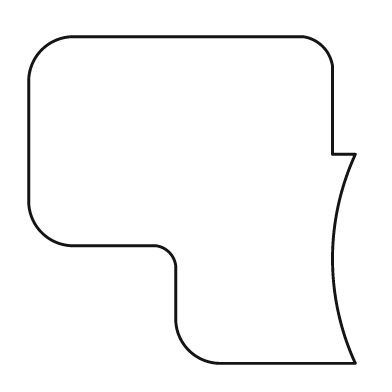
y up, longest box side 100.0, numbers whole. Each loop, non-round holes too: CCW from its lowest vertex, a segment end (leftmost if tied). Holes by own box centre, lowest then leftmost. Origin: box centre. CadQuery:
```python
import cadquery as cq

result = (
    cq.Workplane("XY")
    .moveTo(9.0, -50.0)
    .lineTo(50.0, -50.0)
    .threePointArc((43.0, -18.0), (50.0, 14.0))
    .lineTo(43.0, 14.0)
    .lineTo(43.0, 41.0)
    .threePointArc((40.0, 47.0), (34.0, 50.0))
    .lineTo(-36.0, 50.0)
    .threePointArc((-46.0, 46.0), (-50.0, 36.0))
    .lineTo(-50.0, 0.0)
    .threePointArc((-46.0, -10.0), (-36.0, -14.0))
    .lineTo(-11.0, -14.0)
    .threePointArc((-7.0, -16.0), (-5.0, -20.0))
    .lineTo(-5.0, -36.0)
    .threePointArc((-1.0, -46.0), (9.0, -50.0))
    .close()
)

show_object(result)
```